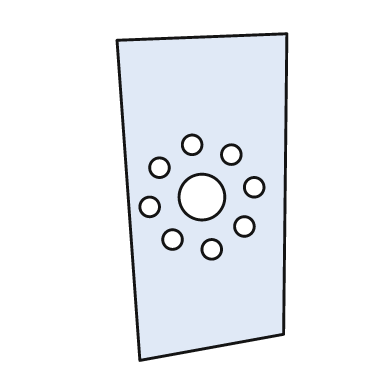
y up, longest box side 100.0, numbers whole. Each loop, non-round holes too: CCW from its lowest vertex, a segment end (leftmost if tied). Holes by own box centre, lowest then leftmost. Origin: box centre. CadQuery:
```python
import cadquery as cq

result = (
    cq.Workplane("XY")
    .moveTo(-19.0, -50.0)
    .lineTo(25.0, -42.0)
    .lineTo(26.0, 50.0)
    .lineTo(-26.0, 48.0)
    .close()
    .moveTo(3.0, -16.0)
    .circle(3.0)
    .moveTo(-9.0, -13.0)
    .circle(3.0)
    .moveTo(13.0, -9.0)
    .circle(3.0)
    .moveTo(-16.0, -3.0)
    .circle(3.0)
    .moveTo(0.0, 0.0)
    .circle(7.0)
    .moveTo(16.0, 3.0)
    .circle(3.0)
    .moveTo(-13.0, 9.0)
    .circle(3.0)
    .moveTo(9.0, 13.0)
    .circle(3.0)
    .moveTo(-3.0, 16.0)
    .circle(3.0)
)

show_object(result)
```